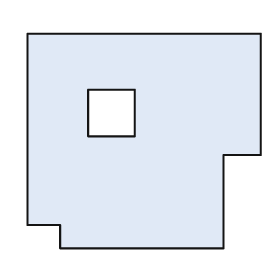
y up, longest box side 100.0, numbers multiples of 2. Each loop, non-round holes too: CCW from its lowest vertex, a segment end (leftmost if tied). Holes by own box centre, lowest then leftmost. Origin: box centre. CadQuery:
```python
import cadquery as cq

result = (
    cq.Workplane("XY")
    .moveTo(-36.0, -46.0)
    .lineTo(34.0, -46.0)
    .lineTo(34.0, -6.0)
    .lineTo(50.0, -6.0)
    .lineTo(50.0, 46.0)
    .lineTo(-50.0, 46.0)
    .lineTo(-50.0, -36.0)
    .lineTo(-36.0, -36.0)
    .close()
    .moveTo(-24.0, 2.0)
    .lineTo(-4.0, 2.0)
    .lineTo(-4.0, 22.0)
    .lineTo(-24.0, 22.0)
    .close()
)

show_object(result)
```